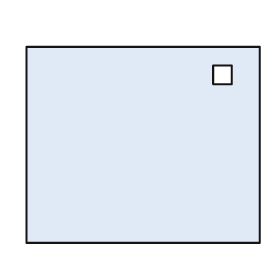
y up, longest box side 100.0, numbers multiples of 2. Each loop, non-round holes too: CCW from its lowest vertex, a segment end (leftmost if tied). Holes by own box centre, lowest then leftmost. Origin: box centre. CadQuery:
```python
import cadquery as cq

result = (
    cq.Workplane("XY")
    .moveTo(-50.0, -42.0)
    .lineTo(50.0, -42.0)
    .lineTo(50.0, 42.0)
    .lineTo(-50.0, 42.0)
    .close()
    .moveTo(30.0, 26.0)
    .lineTo(38.0, 26.0)
    .lineTo(38.0, 34.0)
    .lineTo(30.0, 34.0)
    .close()
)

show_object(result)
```